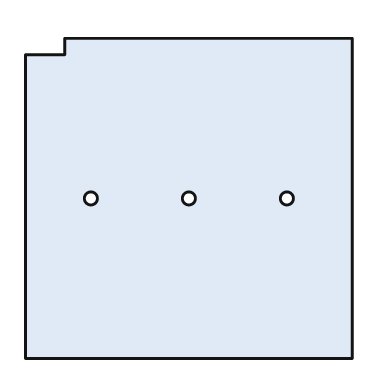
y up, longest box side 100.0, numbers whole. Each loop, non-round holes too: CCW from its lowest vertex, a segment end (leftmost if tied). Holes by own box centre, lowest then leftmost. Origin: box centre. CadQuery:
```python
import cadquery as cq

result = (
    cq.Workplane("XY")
    .moveTo(-50.0, -49.0)
    .lineTo(50.0, -49.0)
    .lineTo(50.0, 49.0)
    .lineTo(-38.0, 49.0)
    .lineTo(-38.0, 44.0)
    .lineTo(-50.0, 44.0)
    .close()
    .moveTo(-30.0, 0.0)
    .circle(2.0)
    .moveTo(0.0, 0.0)
    .circle(2.0)
    .moveTo(30.0, 0.0)
    .circle(2.0)
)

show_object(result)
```